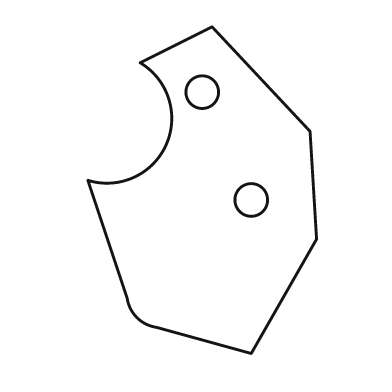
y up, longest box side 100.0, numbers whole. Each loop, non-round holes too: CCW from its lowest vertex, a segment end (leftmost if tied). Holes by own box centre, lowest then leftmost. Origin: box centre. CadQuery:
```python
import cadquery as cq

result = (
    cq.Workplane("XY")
    .moveTo(15.0, -50.0)
    .lineTo(35.0, -15.0)
    .lineTo(33.0, 18.0)
    .lineTo(3.0, 50.0)
    .lineTo(-19.0, 39.0)
    .threePointArc((-11.0, 14.0), (-35.0, 3.0))
    .lineTo(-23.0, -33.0)
    .threePointArc((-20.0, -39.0), (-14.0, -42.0))
    .close()
    .moveTo(15.0, -3.0)
    .circle(5.0)
    .moveTo(0.0, 30.0)
    .circle(5.0)
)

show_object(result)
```